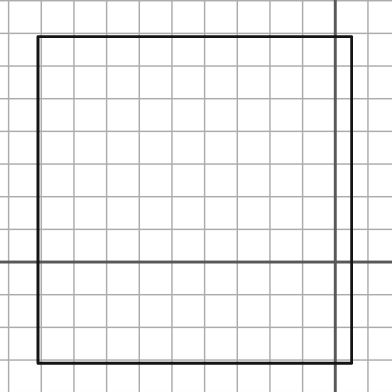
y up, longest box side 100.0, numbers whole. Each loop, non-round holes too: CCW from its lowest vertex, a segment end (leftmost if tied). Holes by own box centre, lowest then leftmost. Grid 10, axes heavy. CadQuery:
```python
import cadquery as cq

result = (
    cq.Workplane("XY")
    .moveTo(-91.0, -31.0)
    .lineTo(5.0, -31.0)
    .lineTo(5.0, 69.0)
    .lineTo(-91.0, 69.0)
    .close()
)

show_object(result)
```